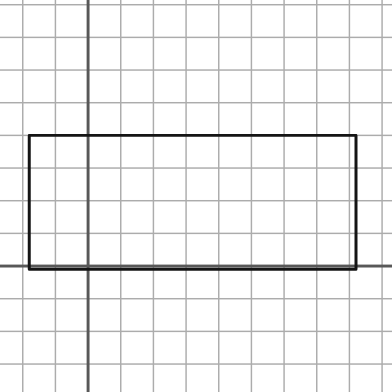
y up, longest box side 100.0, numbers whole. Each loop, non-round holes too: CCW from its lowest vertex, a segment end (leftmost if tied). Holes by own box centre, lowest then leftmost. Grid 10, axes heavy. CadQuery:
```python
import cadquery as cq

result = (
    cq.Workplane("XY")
    .moveTo(-18.0, -1.0)
    .lineTo(82.0, -1.0)
    .lineTo(82.0, 40.0)
    .lineTo(-18.0, 40.0)
    .close()
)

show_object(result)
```